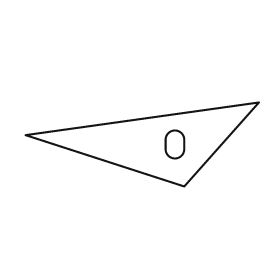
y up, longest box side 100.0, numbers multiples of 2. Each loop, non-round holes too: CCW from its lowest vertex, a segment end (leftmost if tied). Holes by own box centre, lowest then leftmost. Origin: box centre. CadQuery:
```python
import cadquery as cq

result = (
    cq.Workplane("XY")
    .moveTo(18.0, -18.0)
    .lineTo(50.0, 18.0)
    .lineTo(-50.0, 4.0)
    .close()
    .moveTo(10.0, -2.0)
    .threePointArc((14.0, -6.0), (18.0, -2.0))
    .lineTo(18.0, 2.0)
    .threePointArc((14.0, 6.0), (10.0, 2.0))
    .close()
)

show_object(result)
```